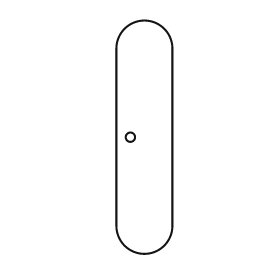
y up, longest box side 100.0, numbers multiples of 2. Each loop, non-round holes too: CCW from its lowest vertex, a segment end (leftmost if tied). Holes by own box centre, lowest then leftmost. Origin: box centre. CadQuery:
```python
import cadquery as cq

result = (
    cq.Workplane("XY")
    .moveTo(-12.0, -38.0)
    .threePointArc((0.0, -50.0), (12.0, -38.0))
    .lineTo(12.0, 38.0)
    .threePointArc((0.0, 50.0), (-12.0, 38.0))
    .close()
    .moveTo(-6.0, 0.0)
    .circle(2.0)
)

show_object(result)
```